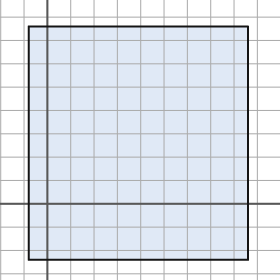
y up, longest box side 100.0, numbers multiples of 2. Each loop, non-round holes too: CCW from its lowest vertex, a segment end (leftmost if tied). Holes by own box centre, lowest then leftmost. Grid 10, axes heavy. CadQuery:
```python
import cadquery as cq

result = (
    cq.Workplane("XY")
    .moveTo(-8.0, -24.0)
    .lineTo(86.0, -24.0)
    .lineTo(86.0, 76.0)
    .lineTo(-8.0, 76.0)
    .close()
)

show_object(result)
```